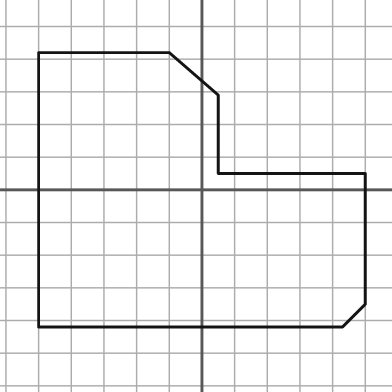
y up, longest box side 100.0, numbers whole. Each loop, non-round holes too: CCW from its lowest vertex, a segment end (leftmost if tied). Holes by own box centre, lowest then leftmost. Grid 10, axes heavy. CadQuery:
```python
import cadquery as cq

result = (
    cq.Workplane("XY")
    .moveTo(-50.0, -42.0)
    .lineTo(43.0, -42.0)
    .lineTo(50.0, -35.0)
    .lineTo(50.0, 5.0)
    .lineTo(5.0, 5.0)
    .lineTo(5.0, 29.0)
    .lineTo(-10.0, 42.0)
    .lineTo(-50.0, 42.0)
    .close()
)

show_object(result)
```